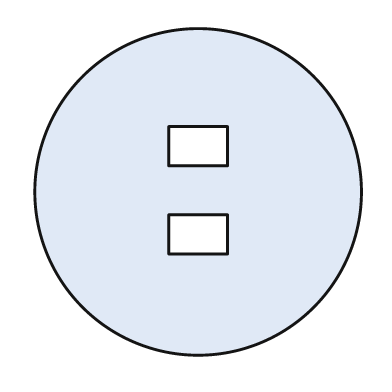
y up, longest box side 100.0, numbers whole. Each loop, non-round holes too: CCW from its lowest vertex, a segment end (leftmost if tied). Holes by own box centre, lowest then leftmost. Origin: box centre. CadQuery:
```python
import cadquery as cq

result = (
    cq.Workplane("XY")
    .moveTo(0.0, 0.0)
    .circle(50.0)
    .moveTo(-9.0, -19.0)
    .lineTo(9.0, -19.0)
    .lineTo(9.0, -7.0)
    .lineTo(-9.0, -7.0)
    .close()
    .moveTo(-9.0, 8.0)
    .lineTo(9.0, 8.0)
    .lineTo(9.0, 20.0)
    .lineTo(-9.0, 20.0)
    .close()
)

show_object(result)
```